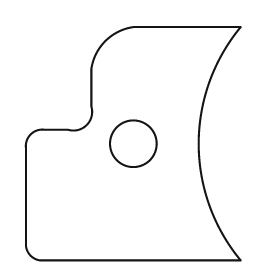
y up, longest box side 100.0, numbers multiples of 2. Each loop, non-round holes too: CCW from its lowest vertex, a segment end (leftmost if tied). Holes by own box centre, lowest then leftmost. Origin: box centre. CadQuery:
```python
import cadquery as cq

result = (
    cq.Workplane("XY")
    .moveTo(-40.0, -50.0)
    .lineTo(46.0, -50.0)
    .threePointArc((28.0, 0.0), (46.0, 50.0))
    .lineTo(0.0, 50.0)
    .threePointArc((-12.0, 44.0), (-18.0, 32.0))
    .lineTo(-18.0, 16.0)
    .threePointArc((-20.0, 8.0), (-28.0, 6.0))
    .lineTo(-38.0, 6.0)
    .threePointArc((-44.0, 4.0), (-46.0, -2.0))
    .lineTo(-46.0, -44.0)
    .threePointArc((-44.0, -48.0), (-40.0, -50.0))
    .close()
    .moveTo(0.0, 0.0)
    .circle(10.0)
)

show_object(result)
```